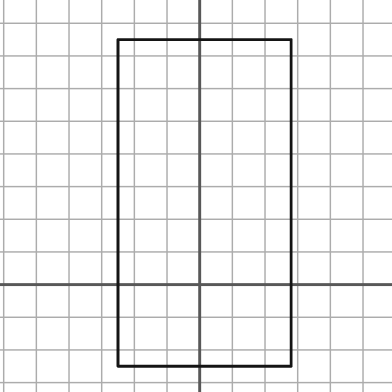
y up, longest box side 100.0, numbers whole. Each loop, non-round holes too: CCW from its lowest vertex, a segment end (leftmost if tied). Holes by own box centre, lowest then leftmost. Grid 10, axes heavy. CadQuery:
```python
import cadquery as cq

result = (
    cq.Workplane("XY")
    .moveTo(-25.0, -25.0)
    .lineTo(28.0, -25.0)
    .lineTo(28.0, 75.0)
    .lineTo(-25.0, 75.0)
    .close()
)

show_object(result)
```